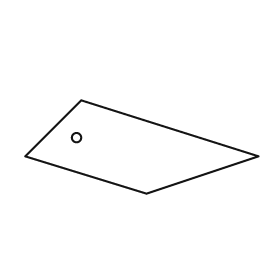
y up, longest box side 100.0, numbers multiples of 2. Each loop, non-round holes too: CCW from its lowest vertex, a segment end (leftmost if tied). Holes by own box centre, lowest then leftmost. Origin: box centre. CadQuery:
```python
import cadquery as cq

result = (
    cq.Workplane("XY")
    .moveTo(2.0, -20.0)
    .lineTo(50.0, -4.0)
    .lineTo(-26.0, 20.0)
    .lineTo(-50.0, -4.0)
    .close()
    .moveTo(-28.0, 4.0)
    .circle(2.0)
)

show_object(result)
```